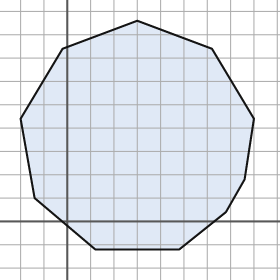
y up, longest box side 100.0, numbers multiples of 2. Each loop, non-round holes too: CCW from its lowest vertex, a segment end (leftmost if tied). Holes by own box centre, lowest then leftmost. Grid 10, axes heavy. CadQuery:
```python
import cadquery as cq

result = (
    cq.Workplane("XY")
    .moveTo(12.0, -12.0)
    .lineTo(48.0, -12.0)
    .lineTo(68.0, 4.0)
    .lineTo(76.0, 18.0)
    .lineTo(80.0, 44.0)
    .lineTo(62.0, 74.0)
    .lineTo(30.0, 86.0)
    .lineTo(-2.0, 74.0)
    .lineTo(-20.0, 44.0)
    .lineTo(-14.0, 10.0)
    .close()
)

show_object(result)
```